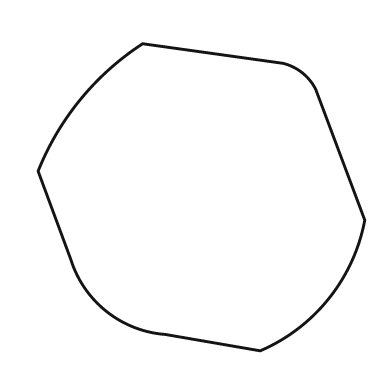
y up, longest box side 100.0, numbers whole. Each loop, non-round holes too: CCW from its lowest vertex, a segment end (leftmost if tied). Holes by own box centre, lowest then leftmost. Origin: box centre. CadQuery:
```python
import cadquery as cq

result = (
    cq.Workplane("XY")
    .moveTo(18.0, -47.0)
    .threePointArc((39.0, -31.0), (50.0, -7.0))
    .lineTo(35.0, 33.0)
    .threePointArc((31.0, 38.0), (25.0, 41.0))
    .lineTo(-18.0, 47.0)
    .threePointArc((-37.0, 30.0), (-50.0, 8.0))
    .lineTo(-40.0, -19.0)
    .threePointArc((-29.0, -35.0), (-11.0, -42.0))
    .close()
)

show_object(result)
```